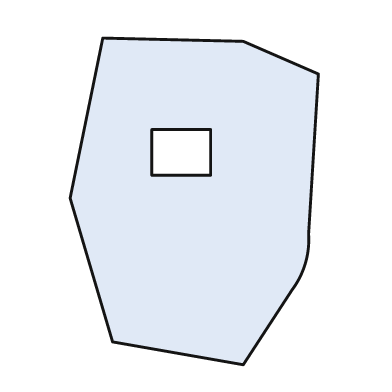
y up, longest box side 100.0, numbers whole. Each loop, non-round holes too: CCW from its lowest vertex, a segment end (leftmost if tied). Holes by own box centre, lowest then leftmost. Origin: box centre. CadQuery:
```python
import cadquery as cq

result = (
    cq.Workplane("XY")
    .moveTo(15.0, -50.0)
    .lineTo(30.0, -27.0)
    .threePointArc((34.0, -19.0), (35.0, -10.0))
    .lineTo(38.0, 39.0)
    .lineTo(15.0, 49.0)
    .lineTo(-28.0, 50.0)
    .lineTo(-38.0, 1.0)
    .lineTo(-25.0, -43.0)
    .close()
    .moveTo(-13.0, 8.0)
    .lineTo(5.0, 8.0)
    .lineTo(5.0, 22.0)
    .lineTo(-13.0, 22.0)
    .close()
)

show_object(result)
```